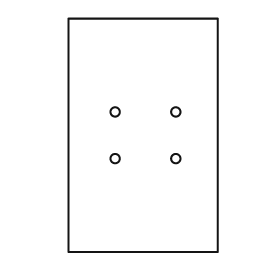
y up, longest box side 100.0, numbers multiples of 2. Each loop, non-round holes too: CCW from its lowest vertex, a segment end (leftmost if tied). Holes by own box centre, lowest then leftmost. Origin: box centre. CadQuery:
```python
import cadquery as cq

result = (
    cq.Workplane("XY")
    .moveTo(-32.0, -50.0)
    .lineTo(32.0, -50.0)
    .lineTo(32.0, 50.0)
    .lineTo(-32.0, 50.0)
    .close()
    .moveTo(-12.0, -10.0)
    .circle(2.0)
    .moveTo(14.0, -10.0)
    .circle(2.0)
    .moveTo(-12.0, 10.0)
    .circle(2.0)
    .moveTo(14.0, 10.0)
    .circle(2.0)
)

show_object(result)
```